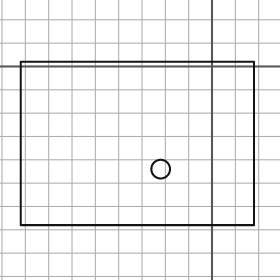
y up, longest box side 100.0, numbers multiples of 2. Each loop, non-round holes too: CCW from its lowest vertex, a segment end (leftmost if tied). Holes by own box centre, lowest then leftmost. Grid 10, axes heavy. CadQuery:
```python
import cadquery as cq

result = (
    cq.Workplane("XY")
    .moveTo(-82.0, -68.0)
    .lineTo(18.0, -68.0)
    .lineTo(18.0, 2.0)
    .lineTo(-82.0, 2.0)
    .close()
    .moveTo(-22.0, -44.0)
    .circle(4.0)
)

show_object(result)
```